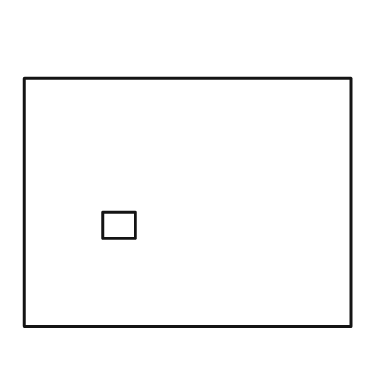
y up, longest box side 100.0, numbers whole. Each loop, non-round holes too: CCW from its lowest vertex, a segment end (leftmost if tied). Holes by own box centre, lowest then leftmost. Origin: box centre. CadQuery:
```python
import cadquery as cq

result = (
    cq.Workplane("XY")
    .moveTo(-50.0, -38.0)
    .lineTo(50.0, -38.0)
    .lineTo(50.0, 38.0)
    .lineTo(-50.0, 38.0)
    .close()
    .moveTo(-26.0, -11.0)
    .lineTo(-16.0, -11.0)
    .lineTo(-16.0, -3.0)
    .lineTo(-26.0, -3.0)
    .close()
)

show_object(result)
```